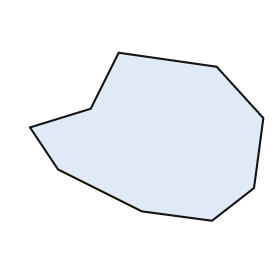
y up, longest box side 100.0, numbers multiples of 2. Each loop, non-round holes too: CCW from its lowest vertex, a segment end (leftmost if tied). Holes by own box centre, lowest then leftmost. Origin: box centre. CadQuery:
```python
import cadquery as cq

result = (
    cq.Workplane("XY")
    .moveTo(28.0, -36.0)
    .lineTo(46.0, -22.0)
    .lineTo(50.0, 8.0)
    .lineTo(30.0, 30.0)
    .lineTo(-12.0, 36.0)
    .lineTo(-24.0, 12.0)
    .lineTo(-50.0, 4.0)
    .lineTo(-38.0, -14.0)
    .lineTo(-2.0, -32.0)
    .close()
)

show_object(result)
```